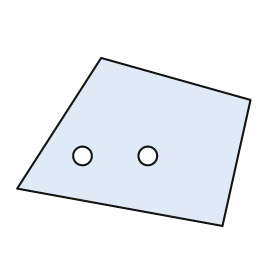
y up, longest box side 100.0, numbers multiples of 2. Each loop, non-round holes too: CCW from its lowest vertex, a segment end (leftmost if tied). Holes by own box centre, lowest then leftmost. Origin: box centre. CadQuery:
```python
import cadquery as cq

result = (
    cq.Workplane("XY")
    .moveTo(38.0, -36.0)
    .lineTo(50.0, 18.0)
    .lineTo(-14.0, 36.0)
    .lineTo(-50.0, -20.0)
    .close()
    .moveTo(-22.0, -6.0)
    .circle(4.0)
    .moveTo(6.0, -6.0)
    .circle(4.0)
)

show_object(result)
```